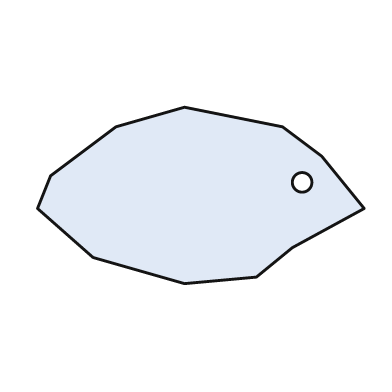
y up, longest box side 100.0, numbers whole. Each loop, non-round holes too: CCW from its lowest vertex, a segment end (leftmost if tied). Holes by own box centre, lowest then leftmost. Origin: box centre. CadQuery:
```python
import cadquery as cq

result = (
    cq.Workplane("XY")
    .moveTo(-5.0, -27.0)
    .lineTo(17.0, -25.0)
    .lineTo(28.0, -16.0)
    .lineTo(50.0, -4.0)
    .lineTo(37.0, 12.0)
    .lineTo(25.0, 21.0)
    .lineTo(-5.0, 27.0)
    .lineTo(-26.0, 21.0)
    .lineTo(-46.0, 6.0)
    .lineTo(-50.0, -4.0)
    .lineTo(-33.0, -19.0)
    .close()
    .moveTo(31.0, 4.0)
    .circle(3.0)
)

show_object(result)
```